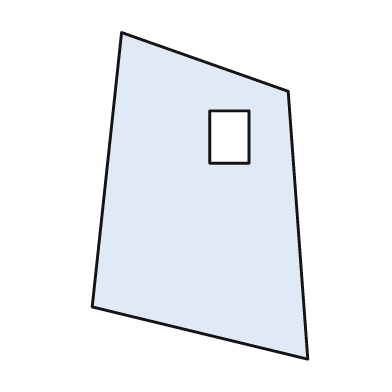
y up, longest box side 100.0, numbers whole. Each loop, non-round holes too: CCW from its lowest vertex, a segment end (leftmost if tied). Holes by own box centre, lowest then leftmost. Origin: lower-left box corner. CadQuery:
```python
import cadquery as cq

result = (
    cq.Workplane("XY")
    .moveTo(66.0, 0.0)
    .lineTo(60.0, 82.0)
    .lineTo(9.0, 100.0)
    .lineTo(0.0, 16.0)
    .close()
    .moveTo(36.0, 60.0)
    .lineTo(48.0, 60.0)
    .lineTo(48.0, 76.0)
    .lineTo(36.0, 76.0)
    .close()
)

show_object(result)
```